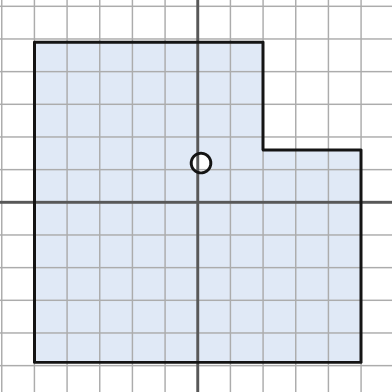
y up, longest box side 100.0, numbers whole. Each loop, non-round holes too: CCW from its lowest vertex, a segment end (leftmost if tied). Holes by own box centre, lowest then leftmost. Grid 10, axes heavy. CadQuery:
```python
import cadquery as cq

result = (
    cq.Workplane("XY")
    .moveTo(-50.0, -49.0)
    .lineTo(50.0, -49.0)
    .lineTo(50.0, 16.0)
    .lineTo(20.0, 16.0)
    .lineTo(20.0, 49.0)
    .lineTo(-50.0, 49.0)
    .close()
    .moveTo(1.0, 12.0)
    .circle(3.0)
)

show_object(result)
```